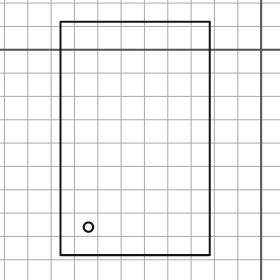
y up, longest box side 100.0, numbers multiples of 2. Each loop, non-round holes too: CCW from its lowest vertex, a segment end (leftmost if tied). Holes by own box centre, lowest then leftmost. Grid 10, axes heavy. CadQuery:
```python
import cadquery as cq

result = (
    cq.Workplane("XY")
    .moveTo(-86.0, -88.0)
    .lineTo(-22.0, -88.0)
    .lineTo(-22.0, 12.0)
    .lineTo(-86.0, 12.0)
    .close()
    .moveTo(-74.0, -76.0)
    .circle(2.0)
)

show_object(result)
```